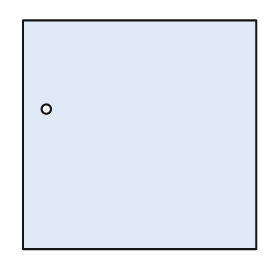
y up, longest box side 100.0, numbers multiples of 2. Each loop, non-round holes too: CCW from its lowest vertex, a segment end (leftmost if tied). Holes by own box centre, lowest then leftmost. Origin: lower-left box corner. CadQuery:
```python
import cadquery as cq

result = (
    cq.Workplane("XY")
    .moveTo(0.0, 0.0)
    .lineTo(100.0, 0.0)
    .lineTo(100.0, 98.0)
    .lineTo(0.0, 98.0)
    .close()
    .moveTo(10.0, 60.0)
    .circle(2.0)
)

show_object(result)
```